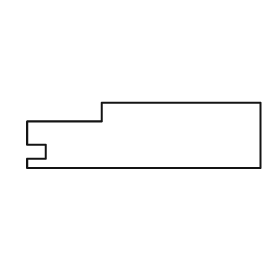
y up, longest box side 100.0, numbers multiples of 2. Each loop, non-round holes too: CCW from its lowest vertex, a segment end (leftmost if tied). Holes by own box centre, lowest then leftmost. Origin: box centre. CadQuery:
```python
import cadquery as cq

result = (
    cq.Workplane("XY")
    .moveTo(-50.0, -14.0)
    .lineTo(50.0, -14.0)
    .lineTo(50.0, 14.0)
    .lineTo(-18.0, 14.0)
    .lineTo(-18.0, 6.0)
    .lineTo(-50.0, 6.0)
    .lineTo(-50.0, -4.0)
    .lineTo(-42.0, -4.0)
    .lineTo(-42.0, -10.0)
    .lineTo(-50.0, -10.0)
    .close()
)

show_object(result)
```